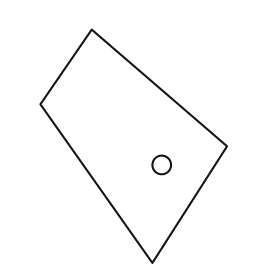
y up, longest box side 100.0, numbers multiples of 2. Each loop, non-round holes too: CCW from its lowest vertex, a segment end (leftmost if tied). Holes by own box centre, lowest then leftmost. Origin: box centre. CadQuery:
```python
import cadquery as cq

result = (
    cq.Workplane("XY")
    .moveTo(8.0, -50.0)
    .lineTo(40.0, 0.0)
    .lineTo(-18.0, 50.0)
    .lineTo(-40.0, 18.0)
    .close()
    .moveTo(12.0, -8.0)
    .circle(4.0)
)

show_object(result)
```